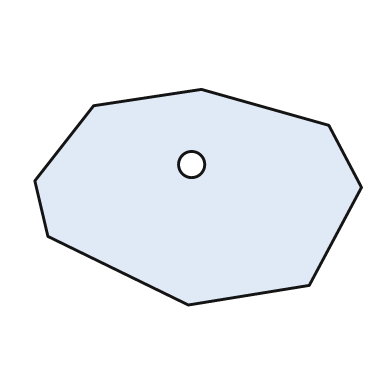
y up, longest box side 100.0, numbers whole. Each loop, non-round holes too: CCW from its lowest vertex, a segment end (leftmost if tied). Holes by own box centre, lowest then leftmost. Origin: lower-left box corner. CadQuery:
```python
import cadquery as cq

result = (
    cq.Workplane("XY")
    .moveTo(47.0, 0.0)
    .lineTo(84.0, 6.0)
    .lineTo(100.0, 36.0)
    .lineTo(90.0, 55.0)
    .lineTo(51.0, 66.0)
    .lineTo(18.0, 61.0)
    .lineTo(0.0, 38.0)
    .lineTo(4.0, 21.0)
    .close()
    .moveTo(48.0, 43.0)
    .circle(4.0)
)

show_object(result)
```